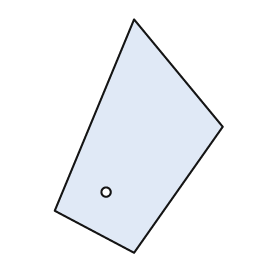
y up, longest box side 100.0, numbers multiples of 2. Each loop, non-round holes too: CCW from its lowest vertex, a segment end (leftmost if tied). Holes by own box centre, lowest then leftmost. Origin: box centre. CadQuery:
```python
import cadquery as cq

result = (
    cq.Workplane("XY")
    .moveTo(-2.0, -50.0)
    .lineTo(36.0, 4.0)
    .lineTo(-2.0, 50.0)
    .lineTo(-36.0, -32.0)
    .close()
    .moveTo(-14.0, -24.0)
    .circle(2.0)
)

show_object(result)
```